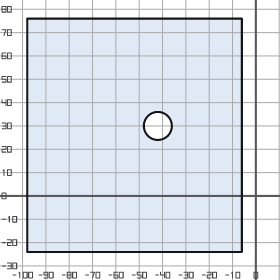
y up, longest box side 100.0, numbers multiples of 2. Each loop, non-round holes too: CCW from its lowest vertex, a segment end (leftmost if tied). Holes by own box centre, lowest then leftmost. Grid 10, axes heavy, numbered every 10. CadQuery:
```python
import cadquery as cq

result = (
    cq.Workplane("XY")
    .moveTo(-98.0, -24.0)
    .lineTo(-6.0, -24.0)
    .lineTo(-6.0, 76.0)
    .lineTo(-98.0, 76.0)
    .close()
    .moveTo(-42.0, 30.0)
    .circle(6.0)
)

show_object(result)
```